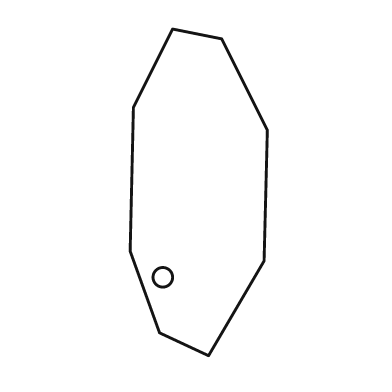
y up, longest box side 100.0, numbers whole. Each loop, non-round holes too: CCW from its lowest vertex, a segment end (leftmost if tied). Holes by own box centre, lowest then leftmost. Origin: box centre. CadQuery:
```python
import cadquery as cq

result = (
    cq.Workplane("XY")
    .moveTo(3.0, -50.0)
    .lineTo(20.0, -21.0)
    .lineTo(21.0, 19.0)
    .lineTo(7.0, 47.0)
    .lineTo(-8.0, 50.0)
    .lineTo(-20.0, 26.0)
    .lineTo(-21.0, -18.0)
    .lineTo(-12.0, -43.0)
    .close()
    .moveTo(-11.0, -26.0)
    .circle(3.0)
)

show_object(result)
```